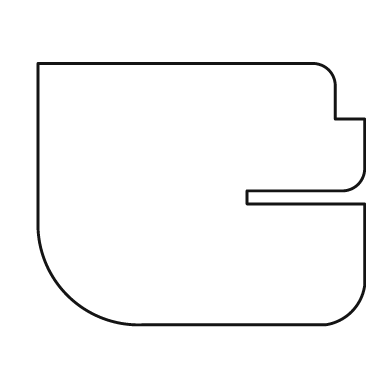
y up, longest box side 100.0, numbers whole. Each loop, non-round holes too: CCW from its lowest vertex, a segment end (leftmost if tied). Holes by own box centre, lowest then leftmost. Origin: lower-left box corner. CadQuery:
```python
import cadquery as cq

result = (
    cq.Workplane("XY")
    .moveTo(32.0, 0.0)
    .lineTo(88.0, 0.0)
    .threePointArc((96.0, 4.0), (100.0, 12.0))
    .lineTo(100.0, 37.0)
    .lineTo(64.0, 37.0)
    .lineTo(64.0, 41.0)
    .lineTo(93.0, 41.0)
    .threePointArc((98.0, 43.0), (100.0, 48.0))
    .lineTo(100.0, 63.0)
    .lineTo(91.0, 63.0)
    .lineTo(91.0, 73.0)
    .threePointArc((89.0, 78.0), (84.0, 80.0))
    .lineTo(0.0, 80.0)
    .lineTo(0.0, 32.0)
    .threePointArc((9.0, 9.0), (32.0, 0.0))
    .close()
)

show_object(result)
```